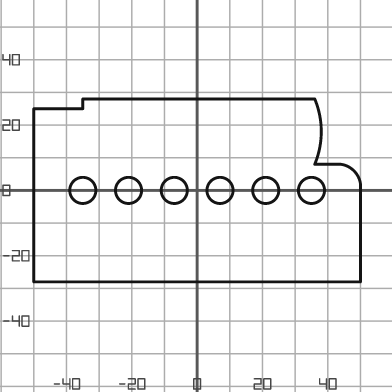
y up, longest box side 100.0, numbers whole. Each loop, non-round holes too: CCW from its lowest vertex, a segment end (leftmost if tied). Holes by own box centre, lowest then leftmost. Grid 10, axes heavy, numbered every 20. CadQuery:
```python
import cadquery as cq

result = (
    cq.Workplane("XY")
    .moveTo(-50.0, -28.0)
    .lineTo(50.0, -28.0)
    .lineTo(50.0, 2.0)
    .threePointArc((48.0, 6.0), (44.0, 8.0))
    .lineTo(36.0, 8.0)
    .threePointArc((38.0, 18.0), (36.0, 28.0))
    .lineTo(-35.0, 28.0)
    .lineTo(-35.0, 25.0)
    .lineTo(-50.0, 25.0)
    .close()
    .moveTo(-35.0, 0.0)
    .circle(4.0)
    .moveTo(-21.0, 0.0)
    .circle(4.0)
    .moveTo(-7.0, 0.0)
    .circle(4.0)
    .moveTo(7.0, 0.0)
    .circle(4.0)
    .moveTo(21.0, 0.0)
    .circle(4.0)
    .moveTo(35.0, 0.0)
    .circle(4.0)
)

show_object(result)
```